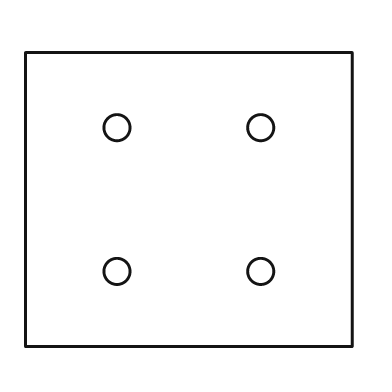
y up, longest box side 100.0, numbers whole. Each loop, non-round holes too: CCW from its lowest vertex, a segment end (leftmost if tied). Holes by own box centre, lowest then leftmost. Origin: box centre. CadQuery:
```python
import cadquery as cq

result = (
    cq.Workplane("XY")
    .moveTo(-50.0, -45.0)
    .lineTo(50.0, -45.0)
    .lineTo(50.0, 45.0)
    .lineTo(-50.0, 45.0)
    .close()
    .moveTo(-22.0, -22.0)
    .circle(4.0)
    .moveTo(22.0, -22.0)
    .circle(4.0)
    .moveTo(-22.0, 22.0)
    .circle(4.0)
    .moveTo(22.0, 22.0)
    .circle(4.0)
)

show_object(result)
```